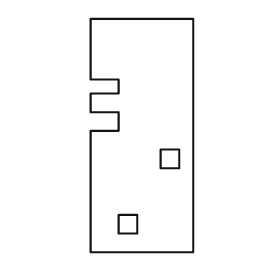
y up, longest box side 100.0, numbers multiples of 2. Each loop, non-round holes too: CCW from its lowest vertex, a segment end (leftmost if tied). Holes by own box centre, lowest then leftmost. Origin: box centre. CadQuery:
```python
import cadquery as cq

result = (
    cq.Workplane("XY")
    .moveTo(-22.0, -50.0)
    .lineTo(22.0, -50.0)
    .lineTo(22.0, 50.0)
    .lineTo(-22.0, 50.0)
    .lineTo(-22.0, 24.0)
    .lineTo(-10.0, 24.0)
    .lineTo(-10.0, 18.0)
    .lineTo(-22.0, 18.0)
    .lineTo(-22.0, 10.0)
    .lineTo(-10.0, 10.0)
    .lineTo(-10.0, 2.0)
    .lineTo(-22.0, 2.0)
    .close()
    .moveTo(-10.0, -42.0)
    .lineTo(-2.0, -42.0)
    .lineTo(-2.0, -34.0)
    .lineTo(-10.0, -34.0)
    .close()
    .moveTo(8.0, -14.0)
    .lineTo(16.0, -14.0)
    .lineTo(16.0, -6.0)
    .lineTo(8.0, -6.0)
    .close()
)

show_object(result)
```